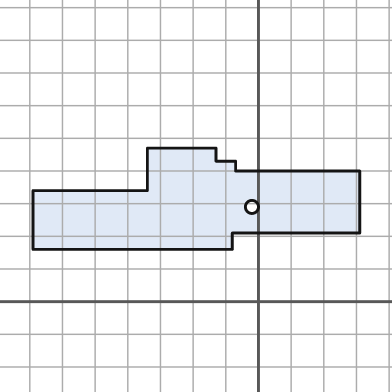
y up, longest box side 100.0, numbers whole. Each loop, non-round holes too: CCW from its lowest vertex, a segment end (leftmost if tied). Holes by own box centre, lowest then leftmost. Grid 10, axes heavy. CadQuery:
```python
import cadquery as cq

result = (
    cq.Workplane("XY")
    .moveTo(-69.0, 16.0)
    .lineTo(-8.0, 16.0)
    .lineTo(-8.0, 21.0)
    .lineTo(31.0, 21.0)
    .lineTo(31.0, 40.0)
    .lineTo(-7.0, 40.0)
    .lineTo(-7.0, 43.0)
    .lineTo(-13.0, 43.0)
    .lineTo(-13.0, 47.0)
    .lineTo(-34.0, 47.0)
    .lineTo(-34.0, 34.0)
    .lineTo(-69.0, 34.0)
    .close()
    .moveTo(-2.0, 29.0)
    .circle(2.0)
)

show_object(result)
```